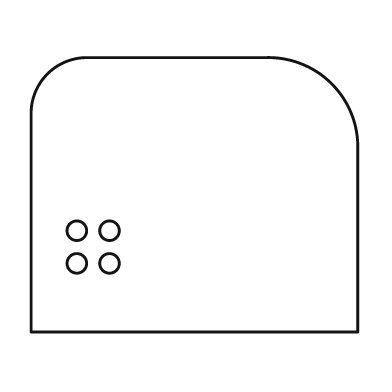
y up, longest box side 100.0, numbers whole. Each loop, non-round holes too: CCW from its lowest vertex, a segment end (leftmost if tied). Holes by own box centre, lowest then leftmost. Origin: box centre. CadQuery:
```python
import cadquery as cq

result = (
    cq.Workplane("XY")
    .moveTo(-50.0, -42.0)
    .lineTo(50.0, -42.0)
    .lineTo(50.0, 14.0)
    .threePointArc((42.0, 34.0), (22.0, 42.0))
    .lineTo(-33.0, 42.0)
    .threePointArc((-45.0, 37.0), (-50.0, 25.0))
    .close()
    .moveTo(-36.0, -21.0)
    .circle(3.0)
    .moveTo(-26.0, -21.0)
    .circle(3.0)
    .moveTo(-36.0, -11.0)
    .circle(3.0)
    .moveTo(-26.0, -11.0)
    .circle(3.0)
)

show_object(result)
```